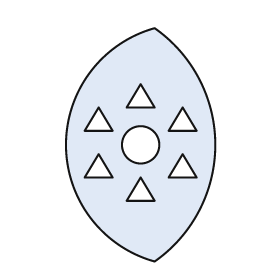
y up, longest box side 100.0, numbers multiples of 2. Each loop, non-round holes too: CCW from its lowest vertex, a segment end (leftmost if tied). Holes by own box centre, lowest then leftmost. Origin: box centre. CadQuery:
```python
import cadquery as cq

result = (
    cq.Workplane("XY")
    .moveTo(6.0, -50.0)
    .threePointArc((32.0, 0.0), (6.0, 50.0))
    .threePointArc((-32.0, 0.0), (6.0, -50.0))
    .close()
    .moveTo(-6.0, -24.0)
    .lineTo(6.0, -24.0)
    .lineTo(0.0, -14.0)
    .close()
    .moveTo(-24.0, -14.0)
    .lineTo(-12.0, -14.0)
    .lineTo(-18.0, -4.0)
    .close()
    .moveTo(12.0, -14.0)
    .lineTo(24.0, -14.0)
    .lineTo(18.0, -4.0)
    .close()
    .moveTo(0.0, 0.0)
    .circle(8.0)
    .moveTo(-24.0, 6.0)
    .lineTo(-12.0, 6.0)
    .lineTo(-18.0, 16.0)
    .close()
    .moveTo(12.0, 6.0)
    .lineTo(24.0, 6.0)
    .lineTo(18.0, 16.0)
    .close()
    .moveTo(-6.0, 16.0)
    .lineTo(6.0, 16.0)
    .lineTo(0.0, 26.0)
    .close()
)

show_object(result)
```